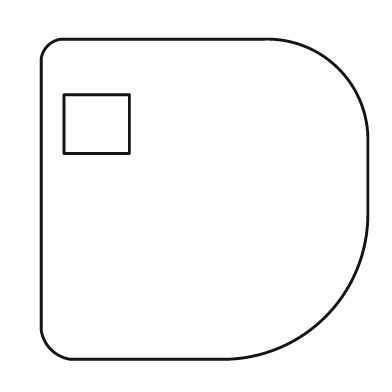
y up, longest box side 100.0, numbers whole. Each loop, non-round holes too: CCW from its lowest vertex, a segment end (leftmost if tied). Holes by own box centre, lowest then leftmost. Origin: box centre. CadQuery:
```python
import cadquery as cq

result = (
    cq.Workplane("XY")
    .moveTo(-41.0, -49.0)
    .lineTo(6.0, -49.0)
    .threePointArc((37.0, -36.0), (50.0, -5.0))
    .lineTo(50.0, 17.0)
    .threePointArc((41.0, 40.0), (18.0, 49.0))
    .lineTo(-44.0, 49.0)
    .threePointArc((-48.0, 47.0), (-50.0, 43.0))
    .lineTo(-50.0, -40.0)
    .threePointArc((-47.0, -46.0), (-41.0, -49.0))
    .close()
    .moveTo(-43.0, 14.0)
    .lineTo(-23.0, 14.0)
    .lineTo(-23.0, 32.0)
    .lineTo(-43.0, 32.0)
    .close()
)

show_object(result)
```